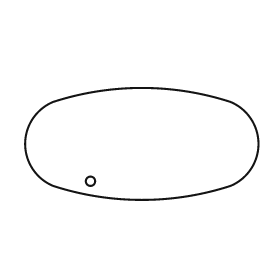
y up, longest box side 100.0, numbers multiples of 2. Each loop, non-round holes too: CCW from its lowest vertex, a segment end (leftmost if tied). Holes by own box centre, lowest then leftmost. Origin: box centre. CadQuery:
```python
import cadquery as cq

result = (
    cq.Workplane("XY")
    .moveTo(-38.0, -18.0)
    .threePointArc((0.0, -24.0), (38.0, -18.0))
    .threePointArc((50.0, 0.0), (38.0, 18.0))
    .threePointArc((0.0, 24.0), (-38.0, 18.0))
    .threePointArc((-50.0, 0.0), (-38.0, -18.0))
    .close()
    .moveTo(-22.0, -16.0)
    .circle(2.0)
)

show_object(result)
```